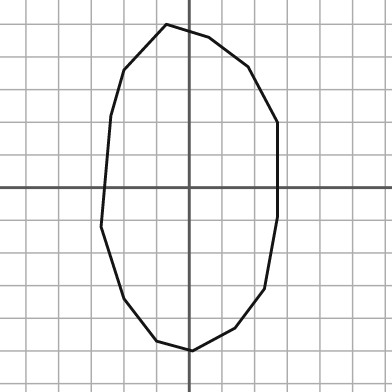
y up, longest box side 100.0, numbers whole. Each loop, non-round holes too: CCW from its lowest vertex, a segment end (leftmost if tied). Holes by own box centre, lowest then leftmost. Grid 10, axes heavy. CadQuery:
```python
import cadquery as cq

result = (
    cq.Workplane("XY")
    .moveTo(1.0, -50.0)
    .lineTo(14.0, -43.0)
    .lineTo(23.0, -31.0)
    .lineTo(27.0, -9.0)
    .lineTo(27.0, 20.0)
    .lineTo(18.0, 37.0)
    .lineTo(6.0, 46.0)
    .lineTo(-7.0, 50.0)
    .lineTo(-20.0, 36.0)
    .lineTo(-24.0, 22.0)
    .lineTo(-27.0, -12.0)
    .lineTo(-20.0, -34.0)
    .lineTo(-10.0, -47.0)
    .close()
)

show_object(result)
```